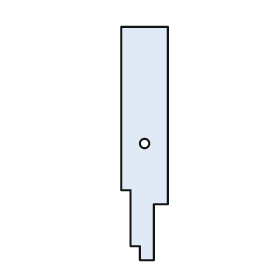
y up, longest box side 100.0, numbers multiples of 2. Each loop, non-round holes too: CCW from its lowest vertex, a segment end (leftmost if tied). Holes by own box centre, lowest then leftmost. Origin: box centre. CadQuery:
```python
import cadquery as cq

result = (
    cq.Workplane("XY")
    .moveTo(-2.0, -50.0)
    .lineTo(4.0, -50.0)
    .lineTo(4.0, -26.0)
    .lineTo(10.0, -26.0)
    .lineTo(10.0, 50.0)
    .lineTo(-10.0, 50.0)
    .lineTo(-10.0, -20.0)
    .lineTo(-6.0, -20.0)
    .lineTo(-6.0, -44.0)
    .lineTo(-2.0, -44.0)
    .close()
    .moveTo(0.0, 0.0)
    .circle(2.0)
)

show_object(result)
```